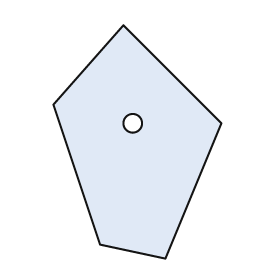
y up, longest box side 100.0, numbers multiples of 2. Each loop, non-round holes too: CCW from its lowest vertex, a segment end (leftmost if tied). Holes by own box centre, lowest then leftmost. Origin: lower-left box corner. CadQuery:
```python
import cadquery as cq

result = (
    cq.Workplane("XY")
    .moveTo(48.0, 0.0)
    .lineTo(72.0, 58.0)
    .lineTo(30.0, 100.0)
    .lineTo(0.0, 66.0)
    .lineTo(20.0, 6.0)
    .close()
    .moveTo(34.0, 58.0)
    .circle(4.0)
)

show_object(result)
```